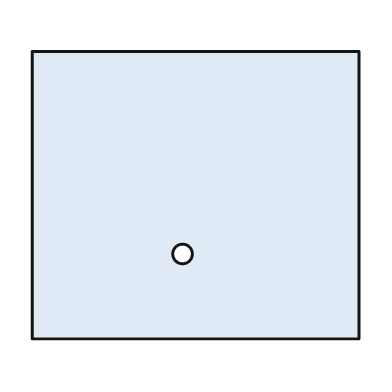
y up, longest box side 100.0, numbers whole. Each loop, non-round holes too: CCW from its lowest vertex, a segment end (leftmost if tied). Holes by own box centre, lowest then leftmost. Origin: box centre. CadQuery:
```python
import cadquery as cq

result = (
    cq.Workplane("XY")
    .moveTo(-50.0, -44.0)
    .lineTo(50.0, -44.0)
    .lineTo(50.0, 44.0)
    .lineTo(-50.0, 44.0)
    .close()
    .moveTo(-4.0, -18.0)
    .circle(3.0)
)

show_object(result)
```